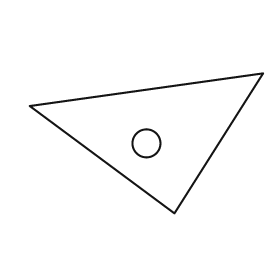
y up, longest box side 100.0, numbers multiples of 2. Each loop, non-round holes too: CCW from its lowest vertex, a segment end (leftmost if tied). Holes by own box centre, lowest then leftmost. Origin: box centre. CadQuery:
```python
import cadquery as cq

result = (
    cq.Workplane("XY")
    .moveTo(12.0, -30.0)
    .lineTo(50.0, 30.0)
    .lineTo(-50.0, 16.0)
    .close()
    .moveTo(0.0, 0.0)
    .circle(6.0)
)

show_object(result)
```